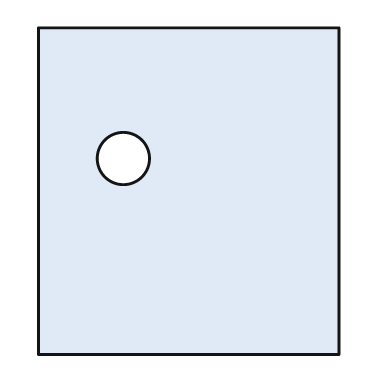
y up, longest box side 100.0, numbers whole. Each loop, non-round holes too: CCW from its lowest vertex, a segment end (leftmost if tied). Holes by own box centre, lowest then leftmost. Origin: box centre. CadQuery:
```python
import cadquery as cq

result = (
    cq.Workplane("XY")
    .moveTo(-46.0, -50.0)
    .lineTo(46.0, -50.0)
    .lineTo(46.0, 50.0)
    .lineTo(-46.0, 50.0)
    .close()
    .moveTo(-20.0, 10.0)
    .circle(8.0)
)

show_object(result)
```